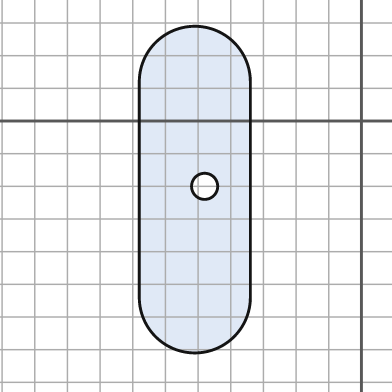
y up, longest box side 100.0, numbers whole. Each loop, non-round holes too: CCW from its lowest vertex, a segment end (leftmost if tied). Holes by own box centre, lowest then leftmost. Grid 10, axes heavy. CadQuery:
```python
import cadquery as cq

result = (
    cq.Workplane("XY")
    .moveTo(-68.0, -54.0)
    .threePointArc((-51.0, -71.0), (-34.0, -54.0))
    .lineTo(-34.0, 12.0)
    .threePointArc((-51.0, 29.0), (-68.0, 12.0))
    .close()
    .moveTo(-48.0, -20.0)
    .circle(4.0)
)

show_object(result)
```